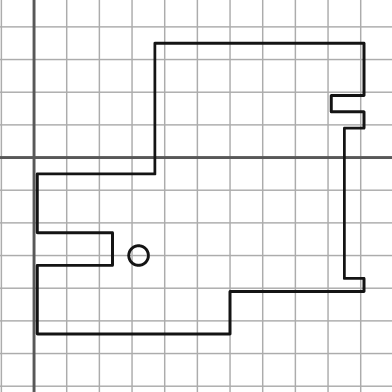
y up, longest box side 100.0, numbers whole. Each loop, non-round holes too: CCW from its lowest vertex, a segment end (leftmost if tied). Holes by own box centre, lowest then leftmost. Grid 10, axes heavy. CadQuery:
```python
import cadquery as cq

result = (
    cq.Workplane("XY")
    .moveTo(1.0, -54.0)
    .lineTo(60.0, -54.0)
    .lineTo(60.0, -41.0)
    .lineTo(101.0, -41.0)
    .lineTo(101.0, -37.0)
    .lineTo(95.0, -37.0)
    .lineTo(95.0, 9.0)
    .lineTo(101.0, 9.0)
    .lineTo(101.0, 14.0)
    .lineTo(91.0, 14.0)
    .lineTo(91.0, 19.0)
    .lineTo(101.0, 19.0)
    .lineTo(101.0, 35.0)
    .lineTo(37.0, 35.0)
    .lineTo(37.0, -5.0)
    .lineTo(1.0, -5.0)
    .lineTo(1.0, -23.0)
    .lineTo(24.0, -23.0)
    .lineTo(24.0, -33.0)
    .lineTo(1.0, -33.0)
    .close()
    .moveTo(32.0, -30.0)
    .circle(3.0)
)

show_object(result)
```